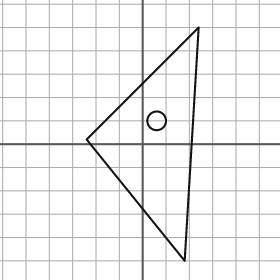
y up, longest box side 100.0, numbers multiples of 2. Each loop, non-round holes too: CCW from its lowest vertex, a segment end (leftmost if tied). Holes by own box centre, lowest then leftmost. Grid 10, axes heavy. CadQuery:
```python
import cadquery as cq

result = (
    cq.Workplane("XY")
    .moveTo(18.0, -50.0)
    .lineTo(24.0, 50.0)
    .lineTo(-24.0, 2.0)
    .close()
    .moveTo(6.0, 10.0)
    .circle(4.0)
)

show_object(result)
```